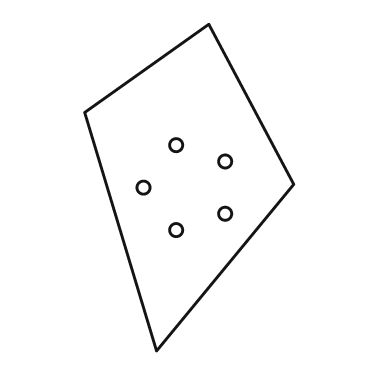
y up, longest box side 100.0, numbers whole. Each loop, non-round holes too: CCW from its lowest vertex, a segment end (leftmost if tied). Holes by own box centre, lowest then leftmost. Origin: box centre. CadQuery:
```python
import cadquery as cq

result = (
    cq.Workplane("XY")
    .moveTo(-10.0, -50.0)
    .lineTo(32.0, 1.0)
    .lineTo(6.0, 50.0)
    .lineTo(-32.0, 23.0)
    .close()
    .moveTo(-4.0, -13.0)
    .circle(2.0)
    .moveTo(11.0, -8.0)
    .circle(2.0)
    .moveTo(-14.0, 0.0)
    .circle(2.0)
    .moveTo(11.0, 8.0)
    .circle(2.0)
    .moveTo(-4.0, 13.0)
    .circle(2.0)
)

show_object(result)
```